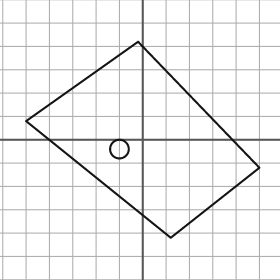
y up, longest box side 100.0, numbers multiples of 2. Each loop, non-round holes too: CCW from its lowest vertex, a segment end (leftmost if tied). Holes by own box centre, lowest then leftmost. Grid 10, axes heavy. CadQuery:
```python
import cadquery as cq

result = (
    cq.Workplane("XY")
    .moveTo(12.0, -42.0)
    .lineTo(50.0, -12.0)
    .lineTo(-2.0, 42.0)
    .lineTo(-50.0, 8.0)
    .close()
    .moveTo(-10.0, -4.0)
    .circle(4.0)
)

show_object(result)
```